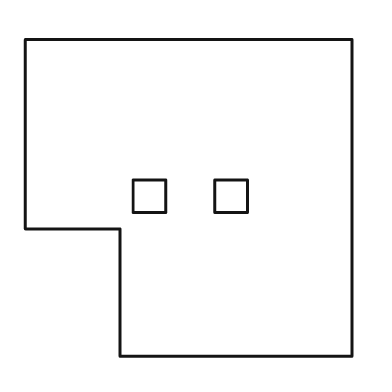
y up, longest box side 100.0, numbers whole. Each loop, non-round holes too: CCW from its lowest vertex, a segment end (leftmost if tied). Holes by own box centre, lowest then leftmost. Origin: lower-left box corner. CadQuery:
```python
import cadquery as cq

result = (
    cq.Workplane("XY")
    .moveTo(29.0, 0.0)
    .lineTo(100.0, 0.0)
    .lineTo(100.0, 97.0)
    .lineTo(0.0, 97.0)
    .lineTo(0.0, 39.0)
    .lineTo(29.0, 39.0)
    .close()
    .moveTo(33.0, 44.0)
    .lineTo(43.0, 44.0)
    .lineTo(43.0, 54.0)
    .lineTo(33.0, 54.0)
    .close()
    .moveTo(58.0, 44.0)
    .lineTo(68.0, 44.0)
    .lineTo(68.0, 54.0)
    .lineTo(58.0, 54.0)
    .close()
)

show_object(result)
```